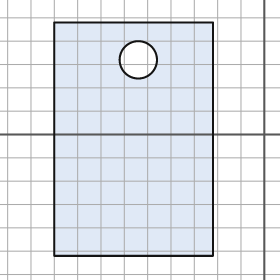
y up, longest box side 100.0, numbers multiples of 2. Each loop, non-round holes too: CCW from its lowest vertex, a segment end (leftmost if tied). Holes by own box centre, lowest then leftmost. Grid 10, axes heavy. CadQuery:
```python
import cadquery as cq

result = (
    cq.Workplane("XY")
    .moveTo(-90.0, -52.0)
    .lineTo(-22.0, -52.0)
    .lineTo(-22.0, 48.0)
    .lineTo(-90.0, 48.0)
    .close()
    .moveTo(-54.0, 32.0)
    .circle(8.0)
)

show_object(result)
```